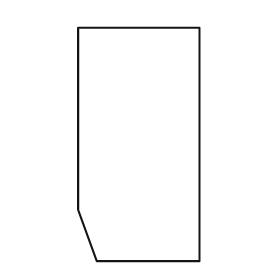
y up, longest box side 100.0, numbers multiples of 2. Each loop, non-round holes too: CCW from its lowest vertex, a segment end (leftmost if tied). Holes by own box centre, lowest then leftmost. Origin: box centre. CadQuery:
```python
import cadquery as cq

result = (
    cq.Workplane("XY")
    .moveTo(-18.0, -50.0)
    .lineTo(26.0, -50.0)
    .lineTo(26.0, 50.0)
    .lineTo(-26.0, 50.0)
    .lineTo(-26.0, -28.0)
    .close()
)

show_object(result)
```